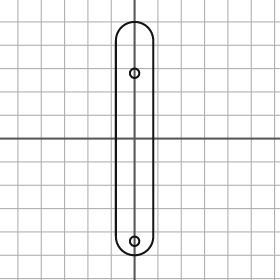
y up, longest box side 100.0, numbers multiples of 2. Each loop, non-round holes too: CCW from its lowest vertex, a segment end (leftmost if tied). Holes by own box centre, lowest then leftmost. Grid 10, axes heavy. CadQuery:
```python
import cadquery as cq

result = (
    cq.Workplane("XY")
    .moveTo(-8.0, -42.0)
    .threePointArc((0.0, -50.0), (8.0, -42.0))
    .lineTo(8.0, 42.0)
    .threePointArc((0.0, 50.0), (-8.0, 42.0))
    .close()
    .moveTo(0.0, -44.0)
    .circle(2.0)
    .moveTo(0.0, 28.0)
    .circle(2.0)
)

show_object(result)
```